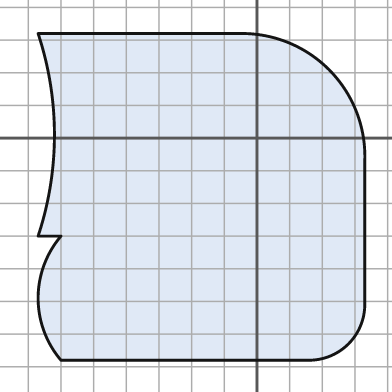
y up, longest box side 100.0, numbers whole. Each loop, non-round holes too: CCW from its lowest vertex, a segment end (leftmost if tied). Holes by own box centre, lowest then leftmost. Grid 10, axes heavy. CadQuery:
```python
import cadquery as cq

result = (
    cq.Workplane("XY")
    .moveTo(-60.0, -68.0)
    .lineTo(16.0, -68.0)
    .threePointArc((28.0, -63.0), (33.0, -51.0))
    .lineTo(33.0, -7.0)
    .threePointArc((22.0, 21.0), (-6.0, 32.0))
    .lineTo(-67.0, 32.0)
    .threePointArc((-62.0, 1.0), (-67.0, -30.0))
    .lineTo(-60.0, -30.0)
    .threePointArc((-67.0, -49.0), (-60.0, -68.0))
    .close()
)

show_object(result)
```